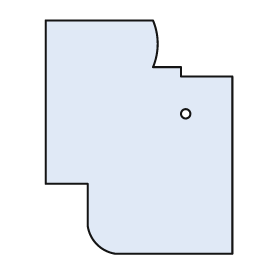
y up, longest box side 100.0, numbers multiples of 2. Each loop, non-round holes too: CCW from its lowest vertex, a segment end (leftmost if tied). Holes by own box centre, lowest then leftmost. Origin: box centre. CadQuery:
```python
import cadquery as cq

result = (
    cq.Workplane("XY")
    .moveTo(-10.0, -50.0)
    .lineTo(40.0, -50.0)
    .lineTo(40.0, 26.0)
    .lineTo(18.0, 26.0)
    .lineTo(18.0, 30.0)
    .lineTo(6.0, 30.0)
    .threePointArc((8.0, 40.0), (6.0, 50.0))
    .lineTo(-40.0, 50.0)
    .lineTo(-40.0, -20.0)
    .lineTo(-22.0, -20.0)
    .lineTo(-22.0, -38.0)
    .threePointArc((-18.0, -46.0), (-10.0, -50.0))
    .close()
    .moveTo(20.0, 10.0)
    .circle(2.0)
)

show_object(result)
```